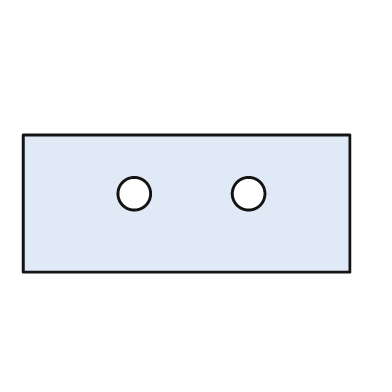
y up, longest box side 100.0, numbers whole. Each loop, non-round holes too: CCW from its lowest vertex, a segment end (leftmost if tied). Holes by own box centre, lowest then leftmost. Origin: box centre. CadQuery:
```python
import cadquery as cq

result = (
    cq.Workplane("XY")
    .moveTo(-50.0, -21.0)
    .lineTo(50.0, -21.0)
    .lineTo(50.0, 21.0)
    .lineTo(-50.0, 21.0)
    .close()
    .moveTo(-16.0, 3.0)
    .circle(5.0)
    .moveTo(19.0, 3.0)
    .circle(5.0)
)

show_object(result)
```